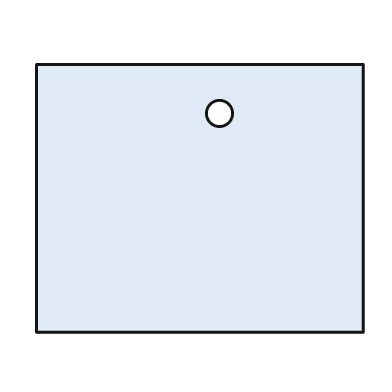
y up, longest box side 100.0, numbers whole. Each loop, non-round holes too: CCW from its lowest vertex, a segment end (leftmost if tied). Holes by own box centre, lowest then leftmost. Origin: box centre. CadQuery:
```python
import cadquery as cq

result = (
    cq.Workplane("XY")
    .moveTo(-50.0, -41.0)
    .lineTo(50.0, -41.0)
    .lineTo(50.0, 41.0)
    .lineTo(-50.0, 41.0)
    .close()
    .moveTo(6.0, 26.0)
    .circle(4.0)
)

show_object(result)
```